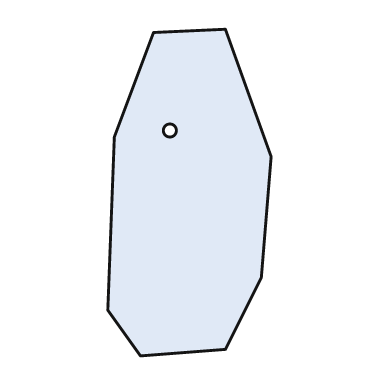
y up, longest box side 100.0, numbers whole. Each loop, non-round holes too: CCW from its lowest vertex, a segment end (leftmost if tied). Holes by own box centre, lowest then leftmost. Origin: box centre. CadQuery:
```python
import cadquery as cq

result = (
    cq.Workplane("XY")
    .moveTo(-15.0, -50.0)
    .lineTo(11.0, -48.0)
    .lineTo(22.0, -26.0)
    .lineTo(25.0, 11.0)
    .lineTo(11.0, 50.0)
    .lineTo(-11.0, 49.0)
    .lineTo(-23.0, 17.0)
    .lineTo(-25.0, -36.0)
    .close()
    .moveTo(-6.0, 19.0)
    .circle(2.0)
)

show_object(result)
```